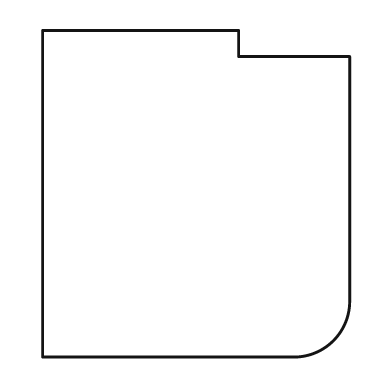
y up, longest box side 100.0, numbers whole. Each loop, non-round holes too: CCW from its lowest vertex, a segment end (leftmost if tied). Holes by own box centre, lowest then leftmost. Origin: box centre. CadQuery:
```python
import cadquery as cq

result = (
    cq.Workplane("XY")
    .moveTo(-47.0, -50.0)
    .lineTo(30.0, -50.0)
    .threePointArc((42.0, -45.0), (47.0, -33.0))
    .lineTo(47.0, 42.0)
    .lineTo(13.0, 42.0)
    .lineTo(13.0, 50.0)
    .lineTo(-47.0, 50.0)
    .close()
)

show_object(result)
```